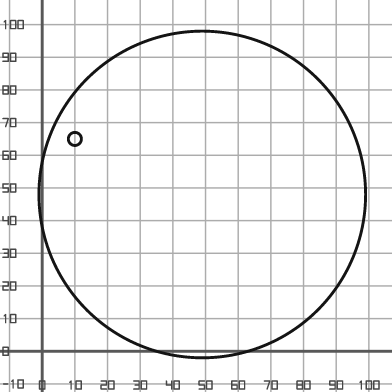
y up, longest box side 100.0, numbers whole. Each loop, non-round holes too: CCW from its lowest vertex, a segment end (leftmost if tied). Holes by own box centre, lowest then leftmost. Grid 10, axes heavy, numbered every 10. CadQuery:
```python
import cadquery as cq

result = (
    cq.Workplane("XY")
    .moveTo(49.0, 48.0)
    .circle(50.0)
    .moveTo(10.0, 65.0)
    .circle(2.0)
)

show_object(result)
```